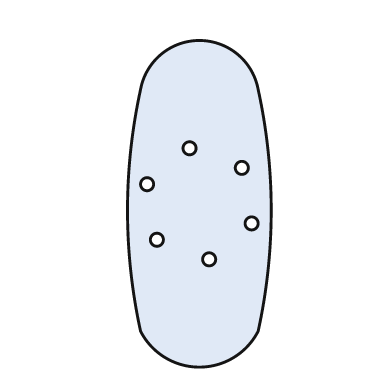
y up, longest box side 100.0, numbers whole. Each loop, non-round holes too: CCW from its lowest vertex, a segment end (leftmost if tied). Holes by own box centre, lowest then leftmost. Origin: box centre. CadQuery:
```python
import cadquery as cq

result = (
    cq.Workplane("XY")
    .moveTo(-18.0, -39.0)
    .threePointArc((0.0, -50.0), (18.0, -39.0))
    .threePointArc((22.0, -2.0), (18.0, 35.0))
    .threePointArc((0.0, 50.0), (-18.0, 35.0))
    .threePointArc((-22.0, -2.0), (-18.0, -39.0))
    .close()
    .moveTo(3.0, -17.0)
    .circle(2.0)
    .moveTo(-13.0, -11.0)
    .circle(2.0)
    .moveTo(16.0, -6.0)
    .circle(2.0)
    .moveTo(-16.0, 6.0)
    .circle(2.0)
    .moveTo(13.0, 11.0)
    .circle(2.0)
    .moveTo(-3.0, 17.0)
    .circle(2.0)
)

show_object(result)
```